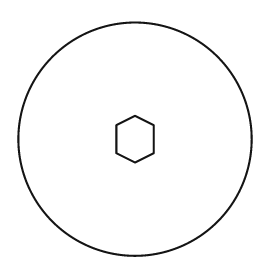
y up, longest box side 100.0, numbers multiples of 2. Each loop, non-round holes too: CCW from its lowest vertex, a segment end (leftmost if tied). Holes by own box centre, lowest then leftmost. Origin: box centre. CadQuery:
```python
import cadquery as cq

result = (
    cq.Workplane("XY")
    .moveTo(0.0, 0.0)
    .circle(50.0)
    .moveTo(0.0, -10.0)
    .lineTo(8.0, -6.0)
    .lineTo(8.0, 6.0)
    .lineTo(0.0, 10.0)
    .lineTo(-8.0, 6.0)
    .lineTo(-8.0, -6.0)
    .close()
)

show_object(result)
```